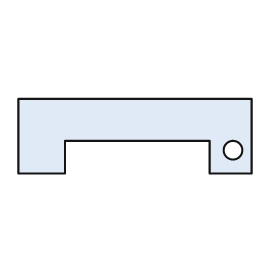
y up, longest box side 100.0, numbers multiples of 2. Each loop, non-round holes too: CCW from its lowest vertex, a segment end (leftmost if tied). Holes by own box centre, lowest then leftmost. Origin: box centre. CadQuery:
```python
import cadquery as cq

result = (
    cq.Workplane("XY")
    .moveTo(-50.0, -16.0)
    .lineTo(-30.0, -16.0)
    .lineTo(-30.0, -2.0)
    .lineTo(32.0, -2.0)
    .lineTo(32.0, -16.0)
    .lineTo(50.0, -16.0)
    .lineTo(50.0, 16.0)
    .lineTo(-50.0, 16.0)
    .close()
    .moveTo(42.0, -6.0)
    .circle(4.0)
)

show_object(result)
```